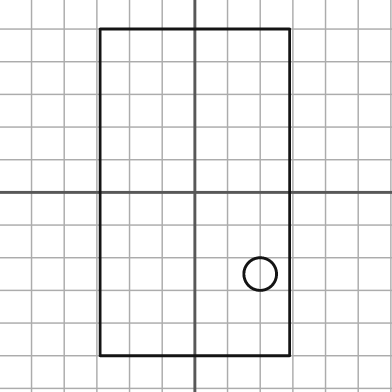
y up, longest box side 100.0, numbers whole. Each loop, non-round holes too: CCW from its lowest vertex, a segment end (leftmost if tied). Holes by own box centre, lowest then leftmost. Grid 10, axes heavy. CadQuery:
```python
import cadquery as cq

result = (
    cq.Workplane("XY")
    .moveTo(-29.0, -50.0)
    .lineTo(29.0, -50.0)
    .lineTo(29.0, 50.0)
    .lineTo(-29.0, 50.0)
    .close()
    .moveTo(20.0, -25.0)
    .circle(5.0)
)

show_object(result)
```